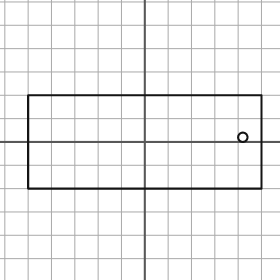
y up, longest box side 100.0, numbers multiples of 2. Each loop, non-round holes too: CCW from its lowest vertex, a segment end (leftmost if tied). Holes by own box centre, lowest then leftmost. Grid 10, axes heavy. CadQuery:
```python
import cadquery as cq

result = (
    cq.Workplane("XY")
    .moveTo(-50.0, -20.0)
    .lineTo(50.0, -20.0)
    .lineTo(50.0, 20.0)
    .lineTo(-50.0, 20.0)
    .close()
    .moveTo(42.0, 2.0)
    .circle(2.0)
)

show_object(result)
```